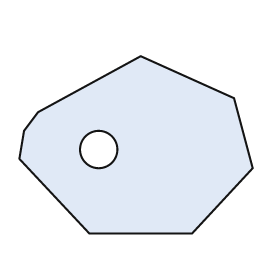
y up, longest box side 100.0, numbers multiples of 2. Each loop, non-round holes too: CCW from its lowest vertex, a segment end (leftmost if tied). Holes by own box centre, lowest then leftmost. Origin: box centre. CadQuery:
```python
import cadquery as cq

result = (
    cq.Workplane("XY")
    .moveTo(-20.0, -38.0)
    .lineTo(24.0, -38.0)
    .lineTo(50.0, -10.0)
    .lineTo(42.0, 20.0)
    .lineTo(2.0, 38.0)
    .lineTo(-42.0, 14.0)
    .lineTo(-48.0, 6.0)
    .lineTo(-50.0, -6.0)
    .close()
    .moveTo(-16.0, -2.0)
    .circle(8.0)
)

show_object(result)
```